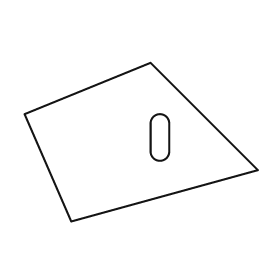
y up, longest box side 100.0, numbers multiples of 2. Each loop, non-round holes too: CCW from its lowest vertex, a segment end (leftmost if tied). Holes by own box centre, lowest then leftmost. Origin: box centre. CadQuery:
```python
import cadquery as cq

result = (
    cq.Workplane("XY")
    .moveTo(-30.0, -34.0)
    .lineTo(50.0, -12.0)
    .lineTo(4.0, 34.0)
    .lineTo(-50.0, 12.0)
    .close()
    .moveTo(4.0, -4.0)
    .threePointArc((8.0, -8.0), (12.0, -4.0))
    .lineTo(12.0, 8.0)
    .threePointArc((8.0, 12.0), (4.0, 8.0))
    .close()
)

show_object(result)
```